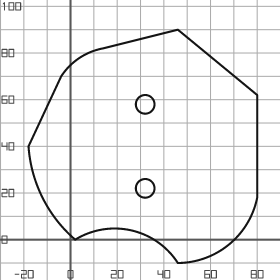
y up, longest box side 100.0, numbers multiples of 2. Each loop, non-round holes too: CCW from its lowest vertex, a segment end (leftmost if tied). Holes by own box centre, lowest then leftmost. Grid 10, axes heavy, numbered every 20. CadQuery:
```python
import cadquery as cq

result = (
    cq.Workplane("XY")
    .moveTo(46.0, -10.0)
    .threePointArc((68.0, -2.0), (80.0, 18.0))
    .lineTo(80.0, 62.0)
    .lineTo(46.0, 90.0)
    .lineTo(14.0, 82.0)
    .threePointArc((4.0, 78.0), (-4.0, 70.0))
    .lineTo(-18.0, 40.0)
    .threePointArc((-12.0, 18.0), (2.0, 0.0))
    .threePointArc((26.0, 4.0), (46.0, -10.0))
    .close()
    .moveTo(32.0, 22.0)
    .circle(4.0)
    .moveTo(32.0, 58.0)
    .circle(4.0)
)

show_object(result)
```